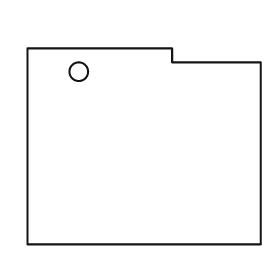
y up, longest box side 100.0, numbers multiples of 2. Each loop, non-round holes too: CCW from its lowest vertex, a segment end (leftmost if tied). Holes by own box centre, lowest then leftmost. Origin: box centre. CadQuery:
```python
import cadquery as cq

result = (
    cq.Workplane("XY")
    .moveTo(-50.0, -42.0)
    .lineTo(50.0, -42.0)
    .lineTo(50.0, 36.0)
    .lineTo(12.0, 36.0)
    .lineTo(12.0, 42.0)
    .lineTo(-50.0, 42.0)
    .close()
    .moveTo(-28.0, 32.0)
    .circle(4.0)
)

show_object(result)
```